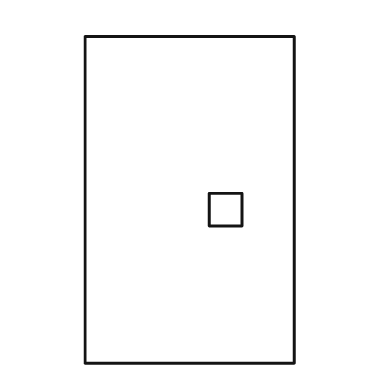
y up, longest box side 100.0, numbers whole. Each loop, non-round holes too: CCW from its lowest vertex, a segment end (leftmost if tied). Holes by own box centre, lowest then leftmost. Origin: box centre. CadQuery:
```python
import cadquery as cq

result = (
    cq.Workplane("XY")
    .moveTo(-32.0, -50.0)
    .lineTo(32.0, -50.0)
    .lineTo(32.0, 50.0)
    .lineTo(-32.0, 50.0)
    .close()
    .moveTo(6.0, -8.0)
    .lineTo(16.0, -8.0)
    .lineTo(16.0, 2.0)
    .lineTo(6.0, 2.0)
    .close()
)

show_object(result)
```